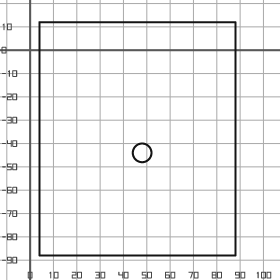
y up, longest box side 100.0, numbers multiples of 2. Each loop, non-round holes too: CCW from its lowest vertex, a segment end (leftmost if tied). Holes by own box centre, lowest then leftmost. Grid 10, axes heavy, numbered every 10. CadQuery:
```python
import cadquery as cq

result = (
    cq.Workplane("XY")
    .moveTo(4.0, -88.0)
    .lineTo(88.0, -88.0)
    .lineTo(88.0, 12.0)
    .lineTo(4.0, 12.0)
    .close()
    .moveTo(48.0, -44.0)
    .circle(4.0)
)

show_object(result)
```